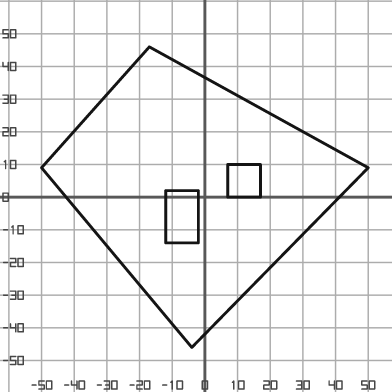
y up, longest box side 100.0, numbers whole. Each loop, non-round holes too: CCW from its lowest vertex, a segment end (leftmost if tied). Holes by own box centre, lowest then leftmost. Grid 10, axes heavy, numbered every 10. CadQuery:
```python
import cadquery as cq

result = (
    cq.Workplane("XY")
    .moveTo(-4.0, -46.0)
    .lineTo(50.0, 9.0)
    .lineTo(-17.0, 46.0)
    .lineTo(-50.0, 9.0)
    .close()
    .moveTo(-12.0, -14.0)
    .lineTo(-2.0, -14.0)
    .lineTo(-2.0, 2.0)
    .lineTo(-12.0, 2.0)
    .close()
    .moveTo(7.0, 0.0)
    .lineTo(17.0, 0.0)
    .lineTo(17.0, 10.0)
    .lineTo(7.0, 10.0)
    .close()
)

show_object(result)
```